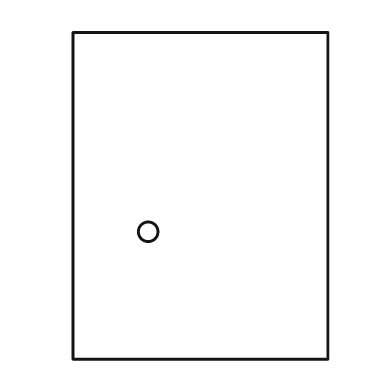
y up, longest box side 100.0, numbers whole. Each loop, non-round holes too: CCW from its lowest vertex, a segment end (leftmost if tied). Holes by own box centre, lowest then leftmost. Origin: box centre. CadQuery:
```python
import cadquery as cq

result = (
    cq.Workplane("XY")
    .moveTo(-39.0, -50.0)
    .lineTo(39.0, -50.0)
    .lineTo(39.0, 50.0)
    .lineTo(-39.0, 50.0)
    .close()
    .moveTo(-16.0, -11.0)
    .circle(3.0)
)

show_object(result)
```